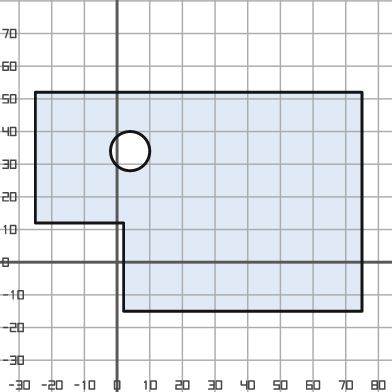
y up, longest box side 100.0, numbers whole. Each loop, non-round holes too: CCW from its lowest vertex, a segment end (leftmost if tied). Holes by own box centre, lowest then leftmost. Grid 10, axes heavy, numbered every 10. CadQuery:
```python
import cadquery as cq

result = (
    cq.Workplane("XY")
    .moveTo(2.0, -15.0)
    .lineTo(75.0, -15.0)
    .lineTo(75.0, 52.0)
    .lineTo(-25.0, 52.0)
    .lineTo(-25.0, 12.0)
    .lineTo(2.0, 12.0)
    .close()
    .moveTo(4.0, 34.0)
    .circle(6.0)
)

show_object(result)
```